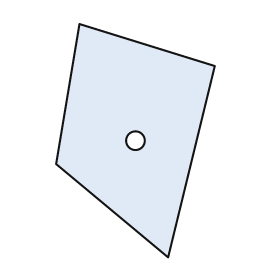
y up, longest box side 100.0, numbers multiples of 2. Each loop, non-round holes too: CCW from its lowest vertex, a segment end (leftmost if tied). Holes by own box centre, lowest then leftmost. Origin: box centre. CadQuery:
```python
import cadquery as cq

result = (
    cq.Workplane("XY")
    .moveTo(14.0, -50.0)
    .lineTo(34.0, 32.0)
    .lineTo(-24.0, 50.0)
    .lineTo(-34.0, -10.0)
    .close()
    .moveTo(0.0, 0.0)
    .circle(4.0)
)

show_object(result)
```